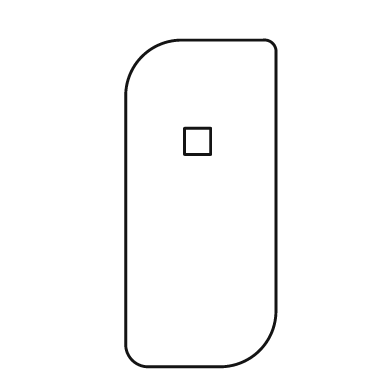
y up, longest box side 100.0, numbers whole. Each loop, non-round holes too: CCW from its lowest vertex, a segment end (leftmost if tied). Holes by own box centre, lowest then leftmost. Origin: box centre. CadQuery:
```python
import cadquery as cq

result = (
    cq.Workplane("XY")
    .moveTo(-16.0, -50.0)
    .lineTo(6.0, -50.0)
    .threePointArc((18.0, -45.0), (23.0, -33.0))
    .lineTo(23.0, 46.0)
    .threePointArc((22.0, 49.0), (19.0, 50.0))
    .lineTo(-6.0, 50.0)
    .threePointArc((-18.0, 45.0), (-23.0, 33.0))
    .lineTo(-23.0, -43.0)
    .threePointArc((-21.0, -48.0), (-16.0, -50.0))
    .close()
    .moveTo(-5.0, 15.0)
    .lineTo(3.0, 15.0)
    .lineTo(3.0, 23.0)
    .lineTo(-5.0, 23.0)
    .close()
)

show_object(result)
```